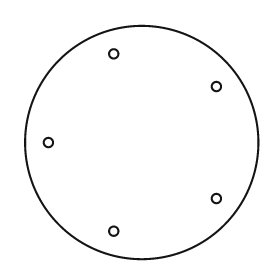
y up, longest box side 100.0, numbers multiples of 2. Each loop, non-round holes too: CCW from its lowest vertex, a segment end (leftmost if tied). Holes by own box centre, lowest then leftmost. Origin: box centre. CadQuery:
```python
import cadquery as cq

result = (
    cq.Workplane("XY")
    .moveTo(0.0, 0.0)
    .circle(50.0)
    .moveTo(-12.0, -38.0)
    .circle(2.0)
    .moveTo(32.0, -24.0)
    .circle(2.0)
    .moveTo(-40.0, 0.0)
    .circle(2.0)
    .moveTo(32.0, 24.0)
    .circle(2.0)
    .moveTo(-12.0, 38.0)
    .circle(2.0)
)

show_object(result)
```